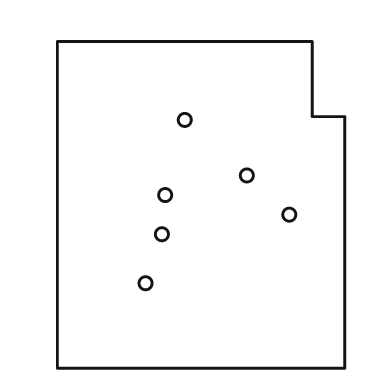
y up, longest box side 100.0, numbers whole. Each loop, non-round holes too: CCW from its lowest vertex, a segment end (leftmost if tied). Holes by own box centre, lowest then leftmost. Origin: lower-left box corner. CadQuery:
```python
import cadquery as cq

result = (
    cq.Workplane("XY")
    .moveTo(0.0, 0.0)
    .lineTo(88.0, 0.0)
    .lineTo(88.0, 77.0)
    .lineTo(78.0, 77.0)
    .lineTo(78.0, 100.0)
    .lineTo(0.0, 100.0)
    .close()
    .moveTo(27.0, 26.0)
    .circle(2.0)
    .moveTo(32.0, 41.0)
    .circle(2.0)
    .moveTo(71.0, 47.0)
    .circle(2.0)
    .moveTo(33.0, 53.0)
    .circle(2.0)
    .moveTo(58.0, 59.0)
    .circle(2.0)
    .moveTo(39.0, 76.0)
    .circle(2.0)
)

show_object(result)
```